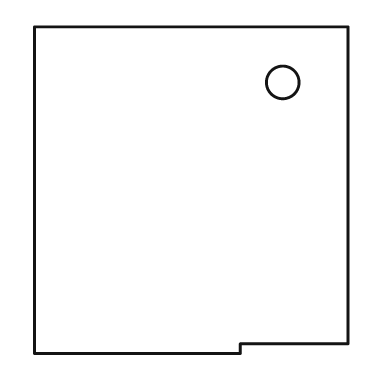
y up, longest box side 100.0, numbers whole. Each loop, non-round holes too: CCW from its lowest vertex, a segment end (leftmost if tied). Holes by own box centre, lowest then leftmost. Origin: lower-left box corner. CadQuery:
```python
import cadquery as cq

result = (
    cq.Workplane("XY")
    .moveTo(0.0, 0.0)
    .lineTo(63.0, 0.0)
    .lineTo(63.0, 3.0)
    .lineTo(96.0, 3.0)
    .lineTo(96.0, 100.0)
    .lineTo(0.0, 100.0)
    .close()
    .moveTo(76.0, 83.0)
    .circle(5.0)
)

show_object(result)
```